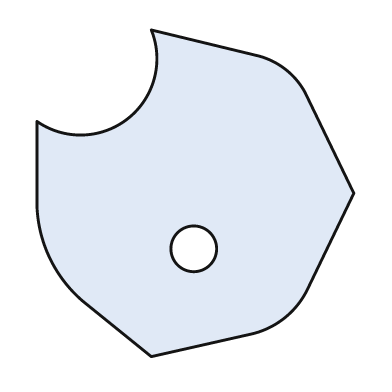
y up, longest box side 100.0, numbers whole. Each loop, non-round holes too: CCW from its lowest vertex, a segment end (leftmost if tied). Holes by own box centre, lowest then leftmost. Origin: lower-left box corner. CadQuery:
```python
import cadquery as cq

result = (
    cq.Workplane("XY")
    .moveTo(35.0, 0.0)
    .lineTo(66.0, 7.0)
    .threePointArc((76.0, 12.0), (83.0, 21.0))
    .lineTo(97.0, 50.0)
    .lineTo(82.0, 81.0)
    .threePointArc((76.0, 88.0), (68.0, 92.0))
    .lineTo(35.0, 100.0)
    .threePointArc((28.0, 73.0), (0.0, 72.0))
    .lineTo(0.0, 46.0)
    .threePointArc((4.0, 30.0), (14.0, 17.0))
    .close()
    .moveTo(48.0, 33.0)
    .circle(7.0)
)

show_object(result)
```